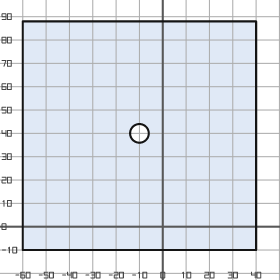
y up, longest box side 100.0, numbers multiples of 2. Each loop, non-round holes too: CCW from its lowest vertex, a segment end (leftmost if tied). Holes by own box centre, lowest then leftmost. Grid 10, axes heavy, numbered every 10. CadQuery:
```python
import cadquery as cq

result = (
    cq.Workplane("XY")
    .moveTo(-60.0, -10.0)
    .lineTo(40.0, -10.0)
    .lineTo(40.0, 88.0)
    .lineTo(-60.0, 88.0)
    .close()
    .moveTo(-10.0, 40.0)
    .circle(4.0)
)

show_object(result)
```